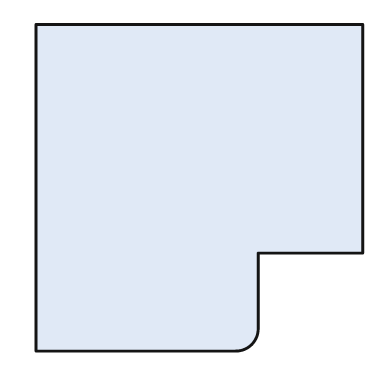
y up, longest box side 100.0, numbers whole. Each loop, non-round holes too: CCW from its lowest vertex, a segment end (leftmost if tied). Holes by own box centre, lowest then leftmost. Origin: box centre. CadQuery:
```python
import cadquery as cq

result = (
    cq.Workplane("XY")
    .moveTo(-50.0, -50.0)
    .lineTo(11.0, -50.0)
    .threePointArc((16.0, -48.0), (18.0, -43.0))
    .lineTo(18.0, -20.0)
    .lineTo(50.0, -20.0)
    .lineTo(50.0, 50.0)
    .lineTo(-50.0, 50.0)
    .close()
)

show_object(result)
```